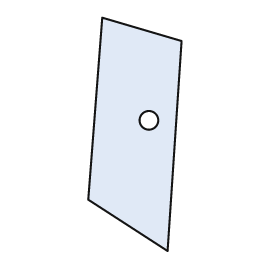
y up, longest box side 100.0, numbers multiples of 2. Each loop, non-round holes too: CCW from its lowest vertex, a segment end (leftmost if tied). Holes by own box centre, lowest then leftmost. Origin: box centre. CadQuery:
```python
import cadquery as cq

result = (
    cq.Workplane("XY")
    .moveTo(14.0, -50.0)
    .lineTo(20.0, 40.0)
    .lineTo(-14.0, 50.0)
    .lineTo(-20.0, -28.0)
    .close()
    .moveTo(6.0, 6.0)
    .circle(4.0)
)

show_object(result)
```